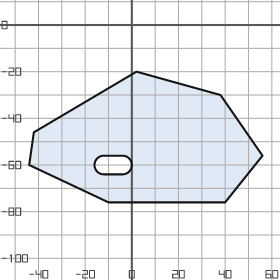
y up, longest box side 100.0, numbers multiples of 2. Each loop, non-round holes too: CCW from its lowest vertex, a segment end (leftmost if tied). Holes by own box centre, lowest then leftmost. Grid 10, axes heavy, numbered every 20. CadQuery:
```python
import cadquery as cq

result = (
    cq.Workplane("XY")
    .moveTo(-10.0, -76.0)
    .lineTo(40.0, -76.0)
    .lineTo(56.0, -56.0)
    .lineTo(38.0, -30.0)
    .lineTo(2.0, -20.0)
    .lineTo(-42.0, -46.0)
    .lineTo(-44.0, -60.0)
    .close()
    .moveTo(-12.0, -64.0)
    .lineTo(-4.0, -64.0)
    .threePointArc((0.0, -60.0), (-4.0, -56.0))
    .lineTo(-12.0, -56.0)
    .threePointArc((-16.0, -60.0), (-12.0, -64.0))
    .close()
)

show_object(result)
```